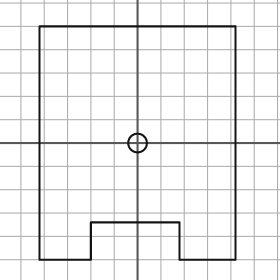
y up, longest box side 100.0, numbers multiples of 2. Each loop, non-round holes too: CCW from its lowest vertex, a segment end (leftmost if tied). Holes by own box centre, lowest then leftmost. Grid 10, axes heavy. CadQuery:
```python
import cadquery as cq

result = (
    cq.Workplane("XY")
    .moveTo(-42.0, -50.0)
    .lineTo(-20.0, -50.0)
    .lineTo(-20.0, -34.0)
    .lineTo(18.0, -34.0)
    .lineTo(18.0, -50.0)
    .lineTo(42.0, -50.0)
    .lineTo(42.0, 50.0)
    .lineTo(-42.0, 50.0)
    .close()
    .moveTo(0.0, 0.0)
    .circle(4.0)
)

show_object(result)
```